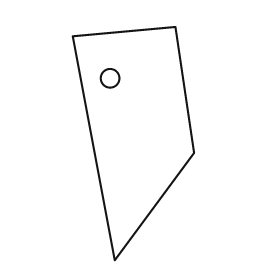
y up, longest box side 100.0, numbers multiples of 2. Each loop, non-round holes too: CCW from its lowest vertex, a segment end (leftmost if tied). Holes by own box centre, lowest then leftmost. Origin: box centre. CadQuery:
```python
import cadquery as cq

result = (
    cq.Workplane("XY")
    .moveTo(-8.0, -50.0)
    .lineTo(26.0, -4.0)
    .lineTo(18.0, 50.0)
    .lineTo(-26.0, 46.0)
    .close()
    .moveTo(-10.0, 28.0)
    .circle(4.0)
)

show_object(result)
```